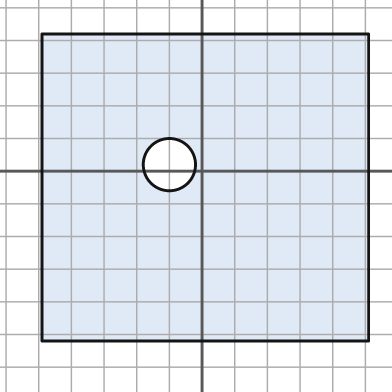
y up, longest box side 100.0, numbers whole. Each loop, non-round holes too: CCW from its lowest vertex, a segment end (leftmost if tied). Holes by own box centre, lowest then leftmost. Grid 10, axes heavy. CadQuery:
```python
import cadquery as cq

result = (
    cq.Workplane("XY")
    .moveTo(-49.0, -52.0)
    .lineTo(51.0, -52.0)
    .lineTo(51.0, 42.0)
    .lineTo(-49.0, 42.0)
    .close()
    .moveTo(-10.0, 2.0)
    .circle(8.0)
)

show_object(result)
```